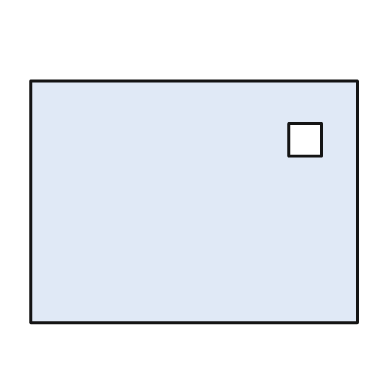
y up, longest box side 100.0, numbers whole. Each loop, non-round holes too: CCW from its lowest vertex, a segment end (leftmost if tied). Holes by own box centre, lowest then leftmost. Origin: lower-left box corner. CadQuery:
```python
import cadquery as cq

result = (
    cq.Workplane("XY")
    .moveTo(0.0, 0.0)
    .lineTo(100.0, 0.0)
    .lineTo(100.0, 74.0)
    .lineTo(0.0, 74.0)
    .close()
    .moveTo(79.0, 51.0)
    .lineTo(89.0, 51.0)
    .lineTo(89.0, 61.0)
    .lineTo(79.0, 61.0)
    .close()
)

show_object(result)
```